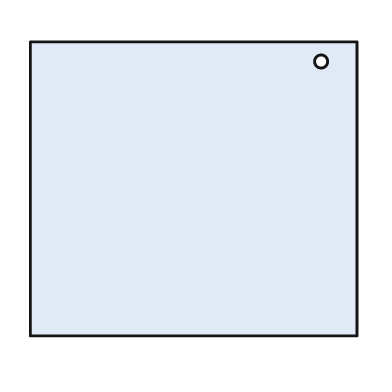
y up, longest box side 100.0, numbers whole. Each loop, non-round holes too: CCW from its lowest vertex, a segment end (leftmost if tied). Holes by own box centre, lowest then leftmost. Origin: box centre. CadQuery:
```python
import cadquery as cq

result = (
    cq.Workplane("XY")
    .moveTo(-50.0, -45.0)
    .lineTo(50.0, -45.0)
    .lineTo(50.0, 45.0)
    .lineTo(-50.0, 45.0)
    .close()
    .moveTo(39.0, 39.0)
    .circle(2.0)
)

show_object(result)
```